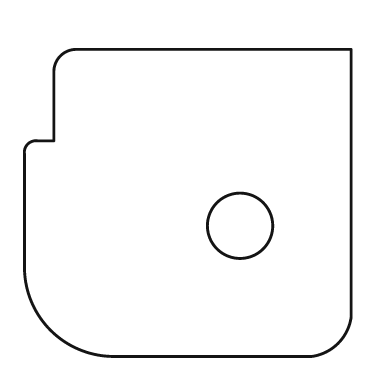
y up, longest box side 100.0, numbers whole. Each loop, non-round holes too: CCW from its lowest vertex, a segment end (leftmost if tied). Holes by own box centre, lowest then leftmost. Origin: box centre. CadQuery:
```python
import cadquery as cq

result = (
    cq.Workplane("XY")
    .moveTo(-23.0, -47.0)
    .lineTo(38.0, -47.0)
    .threePointArc((46.0, -43.0), (50.0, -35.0))
    .lineTo(50.0, 47.0)
    .lineTo(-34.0, 47.0)
    .threePointArc((-39.0, 45.0), (-41.0, 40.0))
    .lineTo(-41.0, 19.0)
    .lineTo(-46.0, 19.0)
    .threePointArc((-49.0, 18.0), (-50.0, 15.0))
    .lineTo(-50.0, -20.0)
    .threePointArc((-42.0, -39.0), (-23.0, -47.0))
    .close()
    .moveTo(16.0, -7.0)
    .circle(10.0)
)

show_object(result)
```